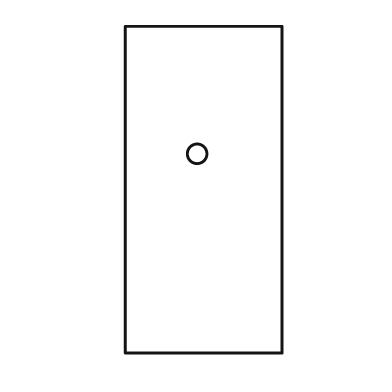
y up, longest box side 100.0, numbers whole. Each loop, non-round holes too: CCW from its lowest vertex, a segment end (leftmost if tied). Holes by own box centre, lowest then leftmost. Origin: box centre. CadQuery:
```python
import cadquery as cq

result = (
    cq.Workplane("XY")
    .moveTo(-24.0, -50.0)
    .lineTo(24.0, -50.0)
    .lineTo(24.0, 50.0)
    .lineTo(-24.0, 50.0)
    .close()
    .moveTo(-2.0, 11.0)
    .circle(3.0)
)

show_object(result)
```